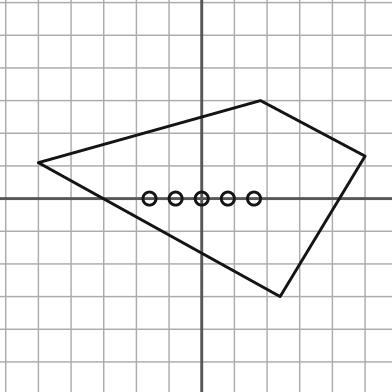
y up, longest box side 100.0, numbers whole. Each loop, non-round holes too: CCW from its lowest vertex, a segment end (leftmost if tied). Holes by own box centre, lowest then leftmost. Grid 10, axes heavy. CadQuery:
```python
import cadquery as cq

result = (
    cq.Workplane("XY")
    .moveTo(24.0, -30.0)
    .lineTo(50.0, 13.0)
    .lineTo(18.0, 30.0)
    .lineTo(-50.0, 11.0)
    .close()
    .moveTo(-16.0, 0.0)
    .circle(2.0)
    .moveTo(-8.0, 0.0)
    .circle(2.0)
    .moveTo(0.0, 0.0)
    .circle(2.0)
    .moveTo(8.0, 0.0)
    .circle(2.0)
    .moveTo(16.0, 0.0)
    .circle(2.0)
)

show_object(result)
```